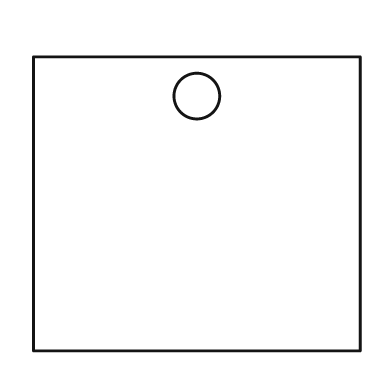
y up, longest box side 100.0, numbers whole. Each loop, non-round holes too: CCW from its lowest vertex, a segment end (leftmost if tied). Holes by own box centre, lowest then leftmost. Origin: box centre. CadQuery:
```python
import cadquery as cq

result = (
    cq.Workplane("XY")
    .moveTo(-50.0, -45.0)
    .lineTo(50.0, -45.0)
    .lineTo(50.0, 45.0)
    .lineTo(-50.0, 45.0)
    .close()
    .moveTo(0.0, 33.0)
    .circle(7.0)
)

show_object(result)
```